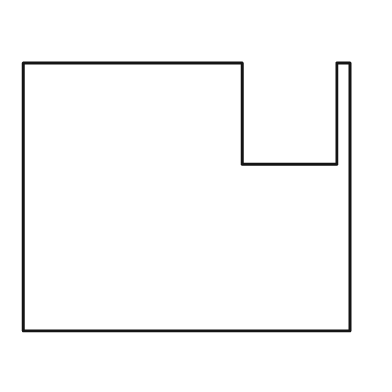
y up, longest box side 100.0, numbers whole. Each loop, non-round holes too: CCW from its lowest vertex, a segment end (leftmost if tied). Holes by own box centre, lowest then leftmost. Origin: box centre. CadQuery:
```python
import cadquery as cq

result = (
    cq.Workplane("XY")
    .moveTo(-50.0, -41.0)
    .lineTo(50.0, -41.0)
    .lineTo(50.0, 41.0)
    .lineTo(46.0, 41.0)
    .lineTo(46.0, 10.0)
    .lineTo(17.0, 10.0)
    .lineTo(17.0, 41.0)
    .lineTo(-50.0, 41.0)
    .close()
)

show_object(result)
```